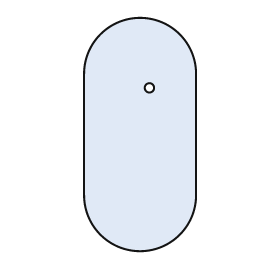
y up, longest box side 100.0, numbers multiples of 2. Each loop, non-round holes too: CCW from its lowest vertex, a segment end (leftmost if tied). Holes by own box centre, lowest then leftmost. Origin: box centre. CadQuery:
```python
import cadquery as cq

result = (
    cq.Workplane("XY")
    .moveTo(-24.0, -26.0)
    .threePointArc((0.0, -50.0), (24.0, -26.0))
    .lineTo(24.0, 26.0)
    .threePointArc((0.0, 50.0), (-24.0, 26.0))
    .close()
    .moveTo(4.0, 20.0)
    .circle(2.0)
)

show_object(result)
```